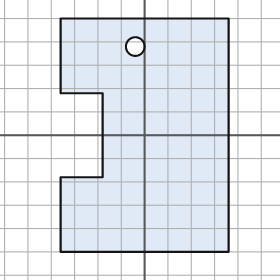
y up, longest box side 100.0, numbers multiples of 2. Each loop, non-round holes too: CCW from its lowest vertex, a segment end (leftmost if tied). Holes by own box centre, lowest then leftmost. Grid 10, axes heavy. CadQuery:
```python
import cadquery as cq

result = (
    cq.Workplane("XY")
    .moveTo(-36.0, -50.0)
    .lineTo(36.0, -50.0)
    .lineTo(36.0, 50.0)
    .lineTo(-36.0, 50.0)
    .lineTo(-36.0, 18.0)
    .lineTo(-18.0, 18.0)
    .lineTo(-18.0, -18.0)
    .lineTo(-36.0, -18.0)
    .close()
    .moveTo(-4.0, 38.0)
    .circle(4.0)
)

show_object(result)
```